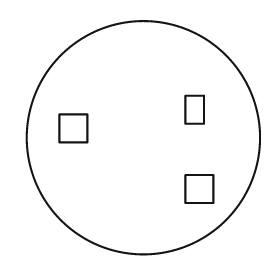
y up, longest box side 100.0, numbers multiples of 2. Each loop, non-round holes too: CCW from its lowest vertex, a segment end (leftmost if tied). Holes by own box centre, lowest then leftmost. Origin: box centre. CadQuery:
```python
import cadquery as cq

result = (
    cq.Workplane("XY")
    .moveTo(0.0, 0.0)
    .circle(50.0)
    .moveTo(18.0, -28.0)
    .lineTo(30.0, -28.0)
    .lineTo(30.0, -16.0)
    .lineTo(18.0, -16.0)
    .close()
    .moveTo(-36.0, -2.0)
    .lineTo(-24.0, -2.0)
    .lineTo(-24.0, 10.0)
    .lineTo(-36.0, 10.0)
    .close()
    .moveTo(18.0, 6.0)
    .lineTo(26.0, 6.0)
    .lineTo(26.0, 18.0)
    .lineTo(18.0, 18.0)
    .close()
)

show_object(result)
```